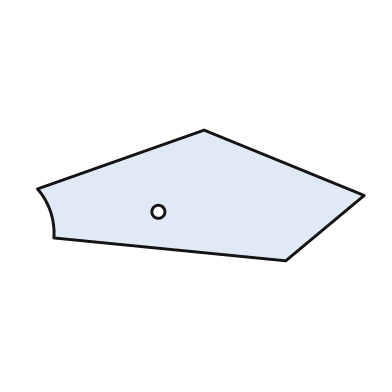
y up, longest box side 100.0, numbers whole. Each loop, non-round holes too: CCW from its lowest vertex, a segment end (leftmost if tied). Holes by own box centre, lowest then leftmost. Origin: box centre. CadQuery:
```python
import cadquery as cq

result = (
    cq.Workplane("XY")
    .moveTo(26.0, -20.0)
    .lineTo(50.0, 0.0)
    .lineTo(1.0, 20.0)
    .lineTo(-50.0, 2.0)
    .threePointArc((-46.0, -5.0), (-45.0, -13.0))
    .close()
    .moveTo(-13.0, -5.0)
    .circle(2.0)
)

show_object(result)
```